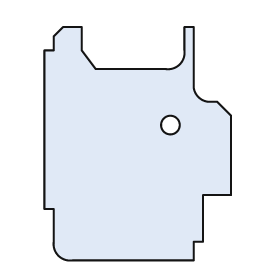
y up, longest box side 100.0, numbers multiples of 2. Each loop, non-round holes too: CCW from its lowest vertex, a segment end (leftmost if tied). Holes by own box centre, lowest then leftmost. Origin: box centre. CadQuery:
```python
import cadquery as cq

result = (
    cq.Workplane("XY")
    .moveTo(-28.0, -50.0)
    .lineTo(24.0, -50.0)
    .lineTo(24.0, -42.0)
    .lineTo(28.0, -42.0)
    .lineTo(28.0, -22.0)
    .lineTo(40.0, -22.0)
    .lineTo(40.0, 12.0)
    .lineTo(34.0, 18.0)
    .lineTo(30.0, 18.0)
    .threePointArc((26.0, 20.0), (24.0, 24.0))
    .lineTo(24.0, 50.0)
    .lineTo(20.0, 50.0)
    .lineTo(20.0, 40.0)
    .threePointArc((18.0, 34.0), (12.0, 32.0))
    .lineTo(-18.0, 32.0)
    .lineTo(-24.0, 40.0)
    .lineTo(-24.0, 50.0)
    .lineTo(-32.0, 50.0)
    .lineTo(-36.0, 46.0)
    .lineTo(-36.0, 40.0)
    .lineTo(-40.0, 40.0)
    .lineTo(-40.0, -28.0)
    .lineTo(-36.0, -28.0)
    .lineTo(-36.0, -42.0)
    .threePointArc((-34.0, -48.0), (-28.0, -50.0))
    .close()
    .moveTo(14.0, 8.0)
    .circle(4.0)
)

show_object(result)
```